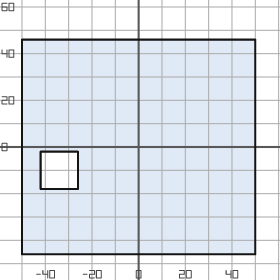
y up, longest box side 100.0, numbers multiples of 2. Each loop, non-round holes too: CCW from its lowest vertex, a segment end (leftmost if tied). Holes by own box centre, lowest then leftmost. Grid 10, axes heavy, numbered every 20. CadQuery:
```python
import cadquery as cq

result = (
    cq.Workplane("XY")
    .moveTo(-50.0, -46.0)
    .lineTo(50.0, -46.0)
    .lineTo(50.0, 46.0)
    .lineTo(-50.0, 46.0)
    .close()
    .moveTo(-42.0, -18.0)
    .lineTo(-26.0, -18.0)
    .lineTo(-26.0, -2.0)
    .lineTo(-42.0, -2.0)
    .close()
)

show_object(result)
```